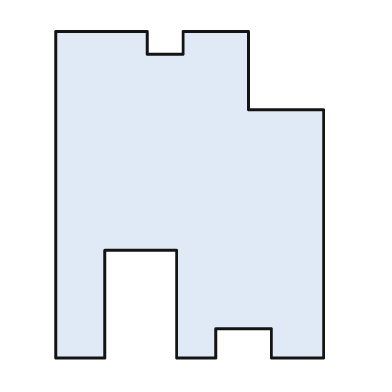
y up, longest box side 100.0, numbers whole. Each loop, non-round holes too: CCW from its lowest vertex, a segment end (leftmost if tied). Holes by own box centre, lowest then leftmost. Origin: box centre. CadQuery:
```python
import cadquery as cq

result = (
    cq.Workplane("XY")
    .moveTo(-41.0, -50.0)
    .lineTo(-26.0, -50.0)
    .lineTo(-26.0, -17.0)
    .lineTo(-4.0, -17.0)
    .lineTo(-4.0, -50.0)
    .lineTo(8.0, -50.0)
    .lineTo(8.0, -41.0)
    .lineTo(25.0, -41.0)
    .lineTo(25.0, -50.0)
    .lineTo(41.0, -50.0)
    .lineTo(41.0, 26.0)
    .lineTo(18.0, 26.0)
    .lineTo(18.0, 50.0)
    .lineTo(-2.0, 50.0)
    .lineTo(-2.0, 43.0)
    .lineTo(-13.0, 43.0)
    .lineTo(-13.0, 50.0)
    .lineTo(-41.0, 50.0)
    .close()
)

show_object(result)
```